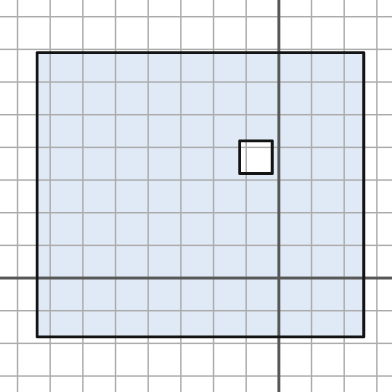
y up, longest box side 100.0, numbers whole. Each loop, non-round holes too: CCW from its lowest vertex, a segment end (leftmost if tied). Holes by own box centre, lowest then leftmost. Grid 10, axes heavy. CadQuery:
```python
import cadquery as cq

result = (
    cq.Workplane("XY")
    .moveTo(-74.0, -18.0)
    .lineTo(26.0, -18.0)
    .lineTo(26.0, 69.0)
    .lineTo(-74.0, 69.0)
    .close()
    .moveTo(-12.0, 32.0)
    .lineTo(-2.0, 32.0)
    .lineTo(-2.0, 42.0)
    .lineTo(-12.0, 42.0)
    .close()
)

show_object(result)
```